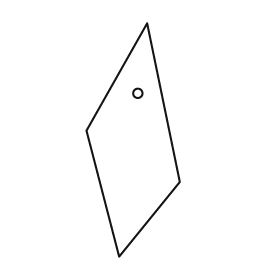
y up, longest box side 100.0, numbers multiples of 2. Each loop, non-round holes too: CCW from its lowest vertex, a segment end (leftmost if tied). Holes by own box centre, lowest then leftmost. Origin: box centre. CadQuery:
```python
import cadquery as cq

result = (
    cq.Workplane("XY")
    .moveTo(-6.0, -50.0)
    .lineTo(20.0, -18.0)
    .lineTo(6.0, 50.0)
    .lineTo(-20.0, 4.0)
    .close()
    .moveTo(2.0, 20.0)
    .circle(2.0)
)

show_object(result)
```